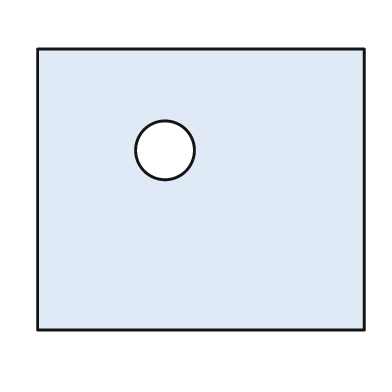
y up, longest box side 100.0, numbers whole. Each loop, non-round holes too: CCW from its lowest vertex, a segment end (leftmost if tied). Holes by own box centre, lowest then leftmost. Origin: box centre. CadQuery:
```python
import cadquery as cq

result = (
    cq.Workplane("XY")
    .moveTo(-50.0, -43.0)
    .lineTo(50.0, -43.0)
    .lineTo(50.0, 43.0)
    .lineTo(-50.0, 43.0)
    .close()
    .moveTo(-11.0, 12.0)
    .circle(9.0)
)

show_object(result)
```